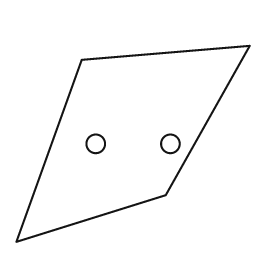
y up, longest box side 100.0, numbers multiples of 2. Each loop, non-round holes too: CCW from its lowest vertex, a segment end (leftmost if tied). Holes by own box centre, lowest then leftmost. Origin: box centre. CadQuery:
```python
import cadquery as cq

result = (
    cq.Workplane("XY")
    .moveTo(-50.0, -42.0)
    .lineTo(14.0, -22.0)
    .lineTo(50.0, 42.0)
    .lineTo(-22.0, 36.0)
    .close()
    .moveTo(-16.0, 0.0)
    .circle(4.0)
    .moveTo(16.0, 0.0)
    .circle(4.0)
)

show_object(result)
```